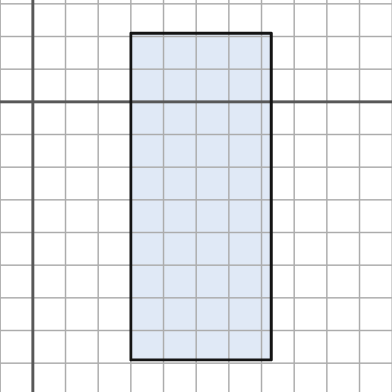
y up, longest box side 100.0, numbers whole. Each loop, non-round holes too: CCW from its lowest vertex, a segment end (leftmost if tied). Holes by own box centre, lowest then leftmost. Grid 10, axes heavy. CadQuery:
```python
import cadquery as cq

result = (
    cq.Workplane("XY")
    .moveTo(30.0, -79.0)
    .lineTo(73.0, -79.0)
    .lineTo(73.0, 21.0)
    .lineTo(30.0, 21.0)
    .close()
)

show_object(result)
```